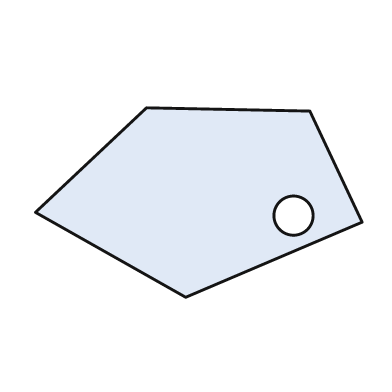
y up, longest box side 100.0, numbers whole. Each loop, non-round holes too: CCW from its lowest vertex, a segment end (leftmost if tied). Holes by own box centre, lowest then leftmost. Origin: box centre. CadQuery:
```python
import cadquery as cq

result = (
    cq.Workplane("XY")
    .moveTo(-4.0, -29.0)
    .lineTo(50.0, -6.0)
    .lineTo(34.0, 28.0)
    .lineTo(-16.0, 29.0)
    .lineTo(-50.0, -3.0)
    .close()
    .moveTo(29.0, -4.0)
    .circle(6.0)
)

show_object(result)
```